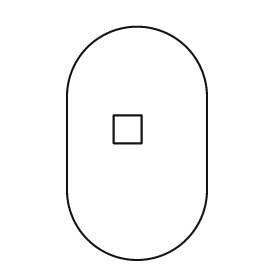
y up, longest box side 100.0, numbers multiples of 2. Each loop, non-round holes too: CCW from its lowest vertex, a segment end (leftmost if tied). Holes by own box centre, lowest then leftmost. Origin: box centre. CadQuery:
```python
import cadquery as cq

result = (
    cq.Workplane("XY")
    .moveTo(-30.0, -20.0)
    .threePointArc((0.0, -50.0), (30.0, -20.0))
    .lineTo(30.0, 20.0)
    .threePointArc((0.0, 50.0), (-30.0, 20.0))
    .close()
    .moveTo(-10.0, 0.0)
    .lineTo(2.0, 0.0)
    .lineTo(2.0, 12.0)
    .lineTo(-10.0, 12.0)
    .close()
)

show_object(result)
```